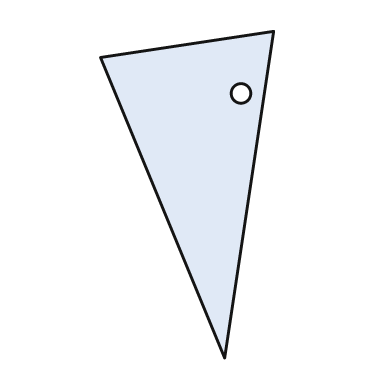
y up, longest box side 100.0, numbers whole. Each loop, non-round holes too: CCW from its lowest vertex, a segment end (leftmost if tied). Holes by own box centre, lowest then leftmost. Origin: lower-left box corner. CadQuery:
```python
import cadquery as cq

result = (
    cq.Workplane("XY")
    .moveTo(38.0, 0.0)
    .lineTo(53.0, 100.0)
    .lineTo(0.0, 92.0)
    .close()
    .moveTo(43.0, 81.0)
    .circle(3.0)
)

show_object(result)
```